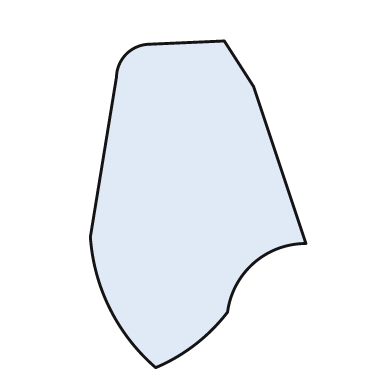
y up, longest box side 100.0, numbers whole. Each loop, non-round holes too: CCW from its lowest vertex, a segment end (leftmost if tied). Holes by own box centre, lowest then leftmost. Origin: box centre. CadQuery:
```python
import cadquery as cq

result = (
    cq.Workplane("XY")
    .moveTo(-13.0, -50.0)
    .threePointArc((-1.0, -43.0), (9.0, -33.0))
    .threePointArc((17.0, -18.0), (33.0, -12.0))
    .lineTo(17.0, 36.0)
    .lineTo(8.0, 50.0)
    .lineTo(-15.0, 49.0)
    .threePointArc((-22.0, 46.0), (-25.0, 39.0))
    .lineTo(-33.0, -10.0)
    .threePointArc((-27.0, -32.0), (-13.0, -50.0))
    .close()
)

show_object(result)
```